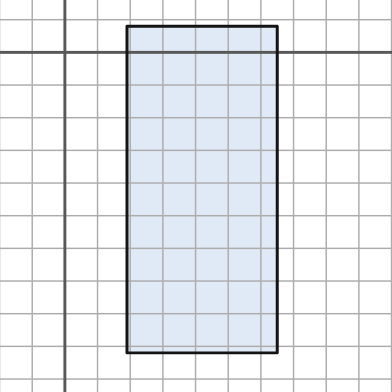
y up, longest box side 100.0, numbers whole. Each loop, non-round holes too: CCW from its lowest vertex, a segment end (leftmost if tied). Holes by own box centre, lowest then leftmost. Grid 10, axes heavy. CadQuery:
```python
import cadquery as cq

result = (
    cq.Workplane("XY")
    .moveTo(19.0, -92.0)
    .lineTo(65.0, -92.0)
    .lineTo(65.0, 8.0)
    .lineTo(19.0, 8.0)
    .close()
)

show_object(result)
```